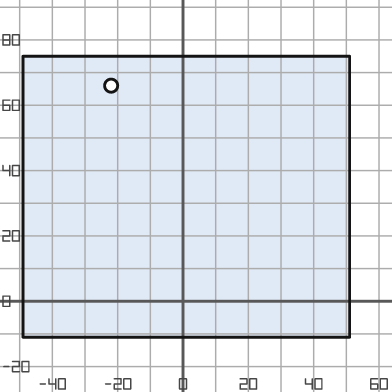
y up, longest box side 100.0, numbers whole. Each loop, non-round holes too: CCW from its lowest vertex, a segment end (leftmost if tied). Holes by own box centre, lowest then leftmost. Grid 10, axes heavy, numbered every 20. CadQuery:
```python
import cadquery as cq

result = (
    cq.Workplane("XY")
    .moveTo(-49.0, -11.0)
    .lineTo(51.0, -11.0)
    .lineTo(51.0, 75.0)
    .lineTo(-49.0, 75.0)
    .close()
    .moveTo(-22.0, 66.0)
    .circle(2.0)
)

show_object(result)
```